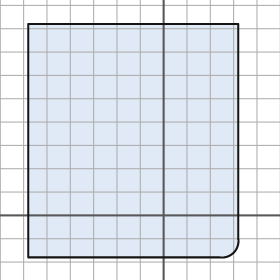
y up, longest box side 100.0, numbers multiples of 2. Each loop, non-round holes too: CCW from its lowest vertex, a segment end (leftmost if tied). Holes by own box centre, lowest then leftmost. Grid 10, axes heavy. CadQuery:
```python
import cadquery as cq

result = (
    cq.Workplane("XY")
    .moveTo(-58.0, -18.0)
    .lineTo(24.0, -18.0)
    .threePointArc((30.0, -16.0), (32.0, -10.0))
    .lineTo(32.0, 82.0)
    .lineTo(-58.0, 82.0)
    .close()
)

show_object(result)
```